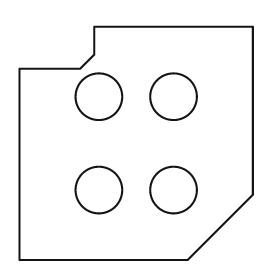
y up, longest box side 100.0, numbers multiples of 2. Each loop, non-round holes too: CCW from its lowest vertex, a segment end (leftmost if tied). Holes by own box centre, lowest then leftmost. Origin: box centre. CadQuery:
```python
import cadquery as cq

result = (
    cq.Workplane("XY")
    .moveTo(-50.0, -50.0)
    .lineTo(22.0, -50.0)
    .lineTo(50.0, -22.0)
    .lineTo(50.0, 50.0)
    .lineTo(-18.0, 50.0)
    .lineTo(-18.0, 38.0)
    .lineTo(-24.0, 32.0)
    .lineTo(-50.0, 32.0)
    .close()
    .moveTo(-16.0, -20.0)
    .circle(10.0)
    .moveTo(16.0, -20.0)
    .circle(10.0)
    .moveTo(-16.0, 20.0)
    .circle(10.0)
    .moveTo(16.0, 20.0)
    .circle(10.0)
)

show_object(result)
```